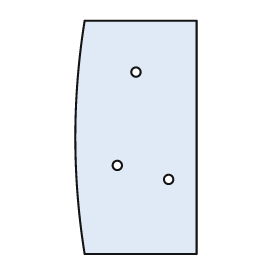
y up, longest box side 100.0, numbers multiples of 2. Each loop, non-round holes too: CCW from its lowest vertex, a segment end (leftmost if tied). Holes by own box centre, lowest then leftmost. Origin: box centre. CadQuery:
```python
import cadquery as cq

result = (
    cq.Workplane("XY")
    .moveTo(-22.0, -50.0)
    .lineTo(26.0, -50.0)
    .lineTo(26.0, 50.0)
    .lineTo(-22.0, 50.0)
    .threePointArc((-26.0, 0.0), (-22.0, -50.0))
    .close()
    .moveTo(14.0, -18.0)
    .circle(2.0)
    .moveTo(-8.0, -12.0)
    .circle(2.0)
    .moveTo(0.0, 28.0)
    .circle(2.0)
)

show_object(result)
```